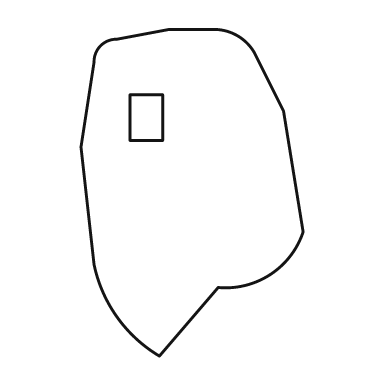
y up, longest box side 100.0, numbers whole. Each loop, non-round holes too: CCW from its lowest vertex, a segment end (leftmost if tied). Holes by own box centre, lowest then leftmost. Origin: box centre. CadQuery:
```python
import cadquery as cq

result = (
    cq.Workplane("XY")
    .moveTo(-10.0, -50.0)
    .lineTo(8.0, -29.0)
    .threePointArc((24.0, -25.0), (34.0, -12.0))
    .lineTo(28.0, 25.0)
    .lineTo(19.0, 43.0)
    .threePointArc((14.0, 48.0), (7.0, 50.0))
    .lineTo(-7.0, 50.0)
    .lineTo(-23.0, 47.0)
    .threePointArc((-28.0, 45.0), (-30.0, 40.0))
    .lineTo(-34.0, 14.0)
    .lineTo(-30.0, -22.0)
    .threePointArc((-23.0, -38.0), (-10.0, -50.0))
    .close()
    .moveTo(-19.0, 16.0)
    .lineTo(-9.0, 16.0)
    .lineTo(-9.0, 30.0)
    .lineTo(-19.0, 30.0)
    .close()
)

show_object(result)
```